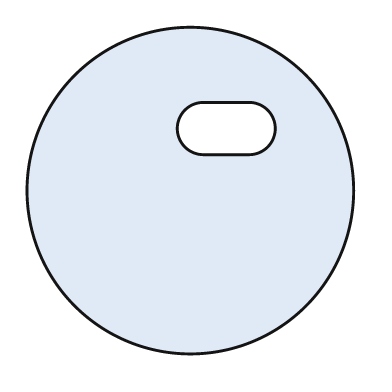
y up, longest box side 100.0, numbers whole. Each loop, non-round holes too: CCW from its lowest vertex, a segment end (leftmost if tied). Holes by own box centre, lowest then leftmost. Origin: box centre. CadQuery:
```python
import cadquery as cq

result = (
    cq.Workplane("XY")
    .moveTo(0.0, 0.0)
    .circle(50.0)
    .moveTo(4.0, 11.0)
    .lineTo(18.0, 11.0)
    .threePointArc((26.0, 19.0), (18.0, 27.0))
    .lineTo(4.0, 27.0)
    .threePointArc((-4.0, 19.0), (4.0, 11.0))
    .close()
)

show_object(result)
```